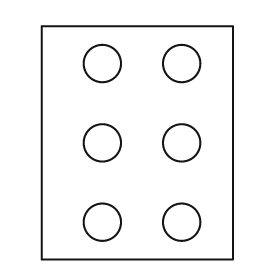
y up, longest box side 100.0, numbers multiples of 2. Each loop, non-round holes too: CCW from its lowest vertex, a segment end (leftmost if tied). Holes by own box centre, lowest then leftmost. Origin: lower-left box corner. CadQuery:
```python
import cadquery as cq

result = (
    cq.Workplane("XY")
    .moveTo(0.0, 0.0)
    .lineTo(82.0, 0.0)
    .lineTo(82.0, 100.0)
    .lineTo(0.0, 100.0)
    .close()
    .moveTo(26.0, 16.0)
    .circle(8.0)
    .moveTo(60.0, 16.0)
    .circle(8.0)
    .moveTo(26.0, 50.0)
    .circle(8.0)
    .moveTo(60.0, 50.0)
    .circle(8.0)
    .moveTo(26.0, 84.0)
    .circle(8.0)
    .moveTo(60.0, 84.0)
    .circle(8.0)
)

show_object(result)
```